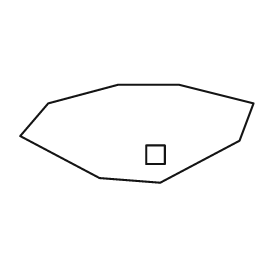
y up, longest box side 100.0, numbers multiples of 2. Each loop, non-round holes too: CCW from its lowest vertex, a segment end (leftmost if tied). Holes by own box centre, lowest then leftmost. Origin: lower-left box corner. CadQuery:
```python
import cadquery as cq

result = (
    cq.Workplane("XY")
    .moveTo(60.0, 0.0)
    .lineTo(94.0, 18.0)
    .lineTo(100.0, 34.0)
    .lineTo(68.0, 42.0)
    .lineTo(42.0, 42.0)
    .lineTo(12.0, 34.0)
    .lineTo(0.0, 20.0)
    .lineTo(34.0, 2.0)
    .close()
    .moveTo(54.0, 8.0)
    .lineTo(62.0, 8.0)
    .lineTo(62.0, 16.0)
    .lineTo(54.0, 16.0)
    .close()
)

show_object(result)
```